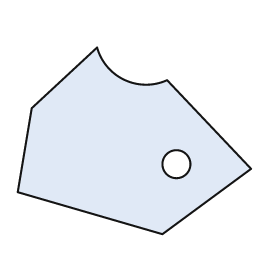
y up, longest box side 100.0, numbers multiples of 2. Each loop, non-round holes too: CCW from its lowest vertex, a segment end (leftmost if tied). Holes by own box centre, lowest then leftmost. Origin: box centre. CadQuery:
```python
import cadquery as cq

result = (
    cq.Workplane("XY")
    .moveTo(12.0, -40.0)
    .lineTo(50.0, -12.0)
    .lineTo(14.0, 26.0)
    .threePointArc((-4.0, 26.0), (-16.0, 40.0))
    .lineTo(-44.0, 14.0)
    .lineTo(-50.0, -22.0)
    .close()
    .moveTo(18.0, -10.0)
    .circle(6.0)
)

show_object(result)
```